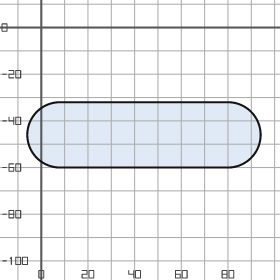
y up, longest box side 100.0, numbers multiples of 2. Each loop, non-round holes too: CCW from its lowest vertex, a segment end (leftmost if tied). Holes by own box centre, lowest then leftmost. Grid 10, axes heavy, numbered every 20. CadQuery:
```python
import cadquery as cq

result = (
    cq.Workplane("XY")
    .moveTo(8.0, -60.0)
    .lineTo(80.0, -60.0)
    .threePointArc((94.0, -46.0), (80.0, -32.0))
    .lineTo(8.0, -32.0)
    .threePointArc((-6.0, -46.0), (8.0, -60.0))
    .close()
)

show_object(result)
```